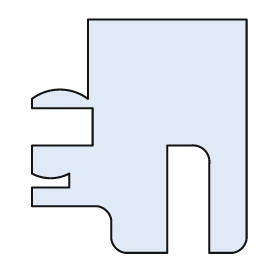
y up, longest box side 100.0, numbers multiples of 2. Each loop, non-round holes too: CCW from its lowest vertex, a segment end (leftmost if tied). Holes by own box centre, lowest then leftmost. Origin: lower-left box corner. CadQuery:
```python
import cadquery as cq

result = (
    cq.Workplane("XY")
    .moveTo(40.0, 0.0)
    .lineTo(58.0, 0.0)
    .lineTo(58.0, 46.0)
    .lineTo(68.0, 46.0)
    .threePointArc((74.0, 44.0), (76.0, 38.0))
    .lineTo(76.0, 0.0)
    .lineTo(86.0, 0.0)
    .threePointArc((90.0, 2.0), (92.0, 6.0))
    .lineTo(92.0, 100.0)
    .lineTo(24.0, 100.0)
    .lineTo(24.0, 66.0)
    .threePointArc((12.0, 70.0), (0.0, 66.0))
    .lineTo(0.0, 62.0)
    .lineTo(26.0, 62.0)
    .lineTo(26.0, 46.0)
    .lineTo(0.0, 46.0)
    .lineTo(0.0, 34.0)
    .threePointArc((8.0, 32.0), (16.0, 34.0))
    .lineTo(16.0, 28.0)
    .lineTo(0.0, 28.0)
    .lineTo(0.0, 20.0)
    .lineTo(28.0, 20.0)
    .threePointArc((32.0, 18.0), (34.0, 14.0))
    .lineTo(34.0, 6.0)
    .threePointArc((36.0, 2.0), (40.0, 0.0))
    .close()
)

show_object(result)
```